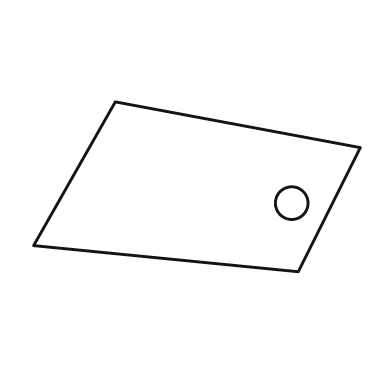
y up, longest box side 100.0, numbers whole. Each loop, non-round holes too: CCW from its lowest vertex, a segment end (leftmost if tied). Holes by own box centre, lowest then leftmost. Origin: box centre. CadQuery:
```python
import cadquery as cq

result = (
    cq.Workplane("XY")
    .moveTo(31.0, -26.0)
    .lineTo(50.0, 12.0)
    .lineTo(-25.0, 26.0)
    .lineTo(-50.0, -18.0)
    .close()
    .moveTo(29.0, -5.0)
    .circle(5.0)
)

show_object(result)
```